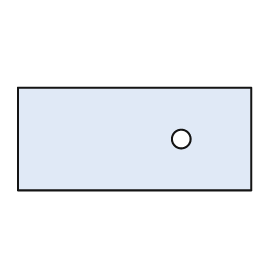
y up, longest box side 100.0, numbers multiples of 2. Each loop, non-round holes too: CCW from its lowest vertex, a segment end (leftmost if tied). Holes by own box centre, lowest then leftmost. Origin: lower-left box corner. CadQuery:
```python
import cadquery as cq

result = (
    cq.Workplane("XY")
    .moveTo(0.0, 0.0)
    .lineTo(100.0, 0.0)
    .lineTo(100.0, 44.0)
    .lineTo(0.0, 44.0)
    .close()
    .moveTo(70.0, 22.0)
    .circle(4.0)
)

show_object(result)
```